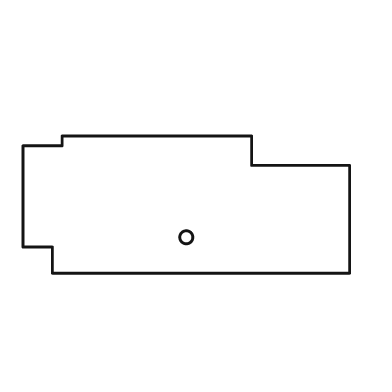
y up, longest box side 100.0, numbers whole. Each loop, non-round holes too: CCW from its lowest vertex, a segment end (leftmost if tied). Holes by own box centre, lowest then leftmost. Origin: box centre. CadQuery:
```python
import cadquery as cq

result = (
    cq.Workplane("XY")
    .moveTo(-41.0, -21.0)
    .lineTo(50.0, -21.0)
    .lineTo(50.0, 12.0)
    .lineTo(20.0, 12.0)
    .lineTo(20.0, 21.0)
    .lineTo(-38.0, 21.0)
    .lineTo(-38.0, 18.0)
    .lineTo(-50.0, 18.0)
    .lineTo(-50.0, -13.0)
    .lineTo(-41.0, -13.0)
    .close()
    .moveTo(0.0, -10.0)
    .circle(2.0)
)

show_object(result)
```